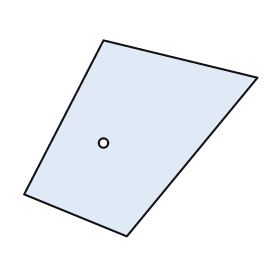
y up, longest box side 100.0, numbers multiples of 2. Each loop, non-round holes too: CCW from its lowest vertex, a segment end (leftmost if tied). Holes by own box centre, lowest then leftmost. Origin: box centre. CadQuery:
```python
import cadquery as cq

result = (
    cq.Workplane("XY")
    .moveTo(-6.0, -42.0)
    .lineTo(50.0, 26.0)
    .lineTo(-16.0, 42.0)
    .lineTo(-50.0, -24.0)
    .close()
    .moveTo(-16.0, -2.0)
    .circle(2.0)
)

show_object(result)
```